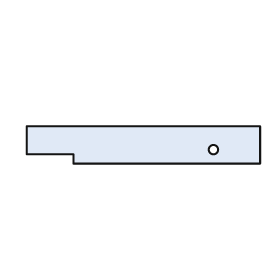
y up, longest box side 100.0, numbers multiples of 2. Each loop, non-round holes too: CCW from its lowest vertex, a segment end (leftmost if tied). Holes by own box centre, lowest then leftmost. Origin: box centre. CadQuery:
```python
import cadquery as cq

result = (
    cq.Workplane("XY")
    .moveTo(-30.0, -8.0)
    .lineTo(50.0, -8.0)
    .lineTo(50.0, 8.0)
    .lineTo(-50.0, 8.0)
    .lineTo(-50.0, -4.0)
    .lineTo(-30.0, -4.0)
    .close()
    .moveTo(30.0, -2.0)
    .circle(2.0)
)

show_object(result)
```